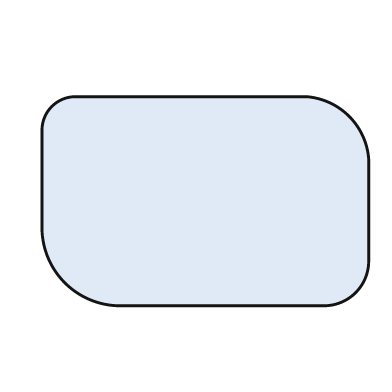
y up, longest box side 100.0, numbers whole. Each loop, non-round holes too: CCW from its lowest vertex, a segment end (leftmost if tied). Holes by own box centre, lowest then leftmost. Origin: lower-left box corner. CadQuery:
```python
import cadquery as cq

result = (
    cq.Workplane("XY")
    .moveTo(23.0, 0.0)
    .lineTo(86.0, 0.0)
    .threePointArc((96.0, 4.0), (100.0, 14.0))
    .lineTo(100.0, 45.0)
    .threePointArc((94.0, 58.0), (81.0, 64.0))
    .lineTo(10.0, 64.0)
    .threePointArc((3.0, 61.0), (0.0, 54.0))
    .lineTo(0.0, 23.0)
    .threePointArc((7.0, 7.0), (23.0, 0.0))
    .close()
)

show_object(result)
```